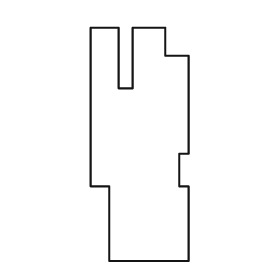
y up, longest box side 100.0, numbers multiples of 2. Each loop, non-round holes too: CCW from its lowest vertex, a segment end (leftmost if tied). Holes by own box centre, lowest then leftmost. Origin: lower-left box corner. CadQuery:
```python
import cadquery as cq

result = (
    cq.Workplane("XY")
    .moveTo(8.0, 0.0)
    .lineTo(42.0, 0.0)
    .lineTo(42.0, 32.0)
    .lineTo(38.0, 32.0)
    .lineTo(38.0, 46.0)
    .lineTo(42.0, 46.0)
    .lineTo(42.0, 88.0)
    .lineTo(32.0, 88.0)
    .lineTo(32.0, 100.0)
    .lineTo(18.0, 100.0)
    .lineTo(18.0, 74.0)
    .lineTo(12.0, 74.0)
    .lineTo(12.0, 100.0)
    .lineTo(0.0, 100.0)
    .lineTo(0.0, 32.0)
    .lineTo(8.0, 32.0)
    .close()
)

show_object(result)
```